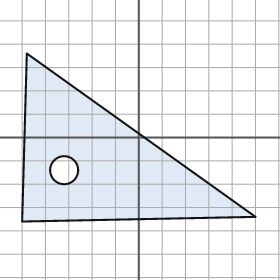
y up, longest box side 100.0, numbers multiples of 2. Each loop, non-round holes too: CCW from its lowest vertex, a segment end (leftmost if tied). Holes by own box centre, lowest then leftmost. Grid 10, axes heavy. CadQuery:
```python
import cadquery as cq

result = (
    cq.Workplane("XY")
    .moveTo(-50.0, -36.0)
    .lineTo(50.0, -34.0)
    .lineTo(-48.0, 36.0)
    .close()
    .moveTo(-32.0, -14.0)
    .circle(6.0)
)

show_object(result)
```